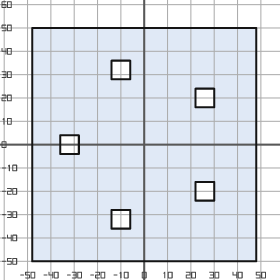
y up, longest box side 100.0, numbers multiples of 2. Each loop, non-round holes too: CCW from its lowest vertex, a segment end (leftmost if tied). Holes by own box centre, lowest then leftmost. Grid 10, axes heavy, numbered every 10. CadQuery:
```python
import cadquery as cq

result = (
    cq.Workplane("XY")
    .moveTo(-48.0, -50.0)
    .lineTo(48.0, -50.0)
    .lineTo(48.0, 50.0)
    .lineTo(-48.0, 50.0)
    .close()
    .moveTo(-14.0, -36.0)
    .lineTo(-6.0, -36.0)
    .lineTo(-6.0, -28.0)
    .lineTo(-14.0, -28.0)
    .close()
    .moveTo(22.0, -24.0)
    .lineTo(30.0, -24.0)
    .lineTo(30.0, -16.0)
    .lineTo(22.0, -16.0)
    .close()
    .moveTo(-36.0, -4.0)
    .lineTo(-28.0, -4.0)
    .lineTo(-28.0, 4.0)
    .lineTo(-36.0, 4.0)
    .close()
    .moveTo(22.0, 16.0)
    .lineTo(30.0, 16.0)
    .lineTo(30.0, 24.0)
    .lineTo(22.0, 24.0)
    .close()
    .moveTo(-14.0, 28.0)
    .lineTo(-6.0, 28.0)
    .lineTo(-6.0, 36.0)
    .lineTo(-14.0, 36.0)
    .close()
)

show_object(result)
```